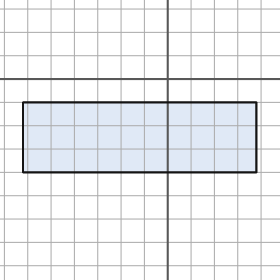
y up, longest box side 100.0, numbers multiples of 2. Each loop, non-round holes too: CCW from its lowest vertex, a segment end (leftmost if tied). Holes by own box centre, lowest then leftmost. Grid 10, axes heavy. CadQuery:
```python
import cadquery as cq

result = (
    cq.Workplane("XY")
    .moveTo(-62.0, -40.0)
    .lineTo(38.0, -40.0)
    .lineTo(38.0, -10.0)
    .lineTo(-62.0, -10.0)
    .close()
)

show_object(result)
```